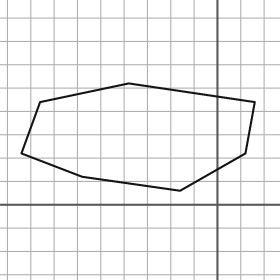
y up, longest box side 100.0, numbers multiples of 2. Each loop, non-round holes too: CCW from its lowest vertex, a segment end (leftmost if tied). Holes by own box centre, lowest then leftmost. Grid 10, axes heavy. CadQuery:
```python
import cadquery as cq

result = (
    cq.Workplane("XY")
    .moveTo(-16.0, 6.0)
    .lineTo(12.0, 22.0)
    .lineTo(16.0, 44.0)
    .lineTo(-38.0, 52.0)
    .lineTo(-76.0, 44.0)
    .lineTo(-84.0, 22.0)
    .lineTo(-58.0, 12.0)
    .close()
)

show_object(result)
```